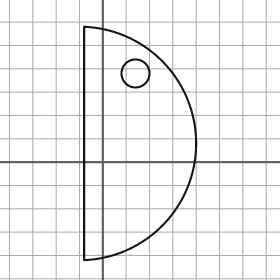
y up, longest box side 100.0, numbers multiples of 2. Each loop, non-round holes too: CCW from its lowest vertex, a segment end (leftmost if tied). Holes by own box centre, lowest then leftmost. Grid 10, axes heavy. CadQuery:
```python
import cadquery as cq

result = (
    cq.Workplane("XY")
    .moveTo(-8.0, -42.0)
    .threePointArc((40.0, 8.0), (-8.0, 58.0))
    .close()
    .moveTo(14.0, 38.0)
    .circle(6.0)
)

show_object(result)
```